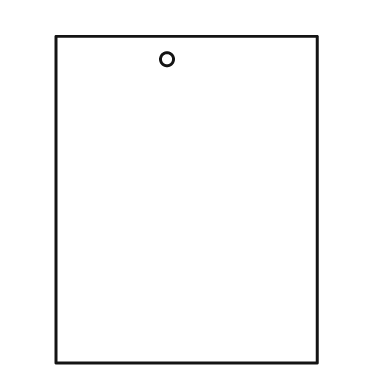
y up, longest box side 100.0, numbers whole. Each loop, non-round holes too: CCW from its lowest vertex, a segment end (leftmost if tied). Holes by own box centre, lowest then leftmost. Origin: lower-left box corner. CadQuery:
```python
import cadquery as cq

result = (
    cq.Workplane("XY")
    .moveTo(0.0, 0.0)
    .lineTo(80.0, 0.0)
    .lineTo(80.0, 100.0)
    .lineTo(0.0, 100.0)
    .close()
    .moveTo(34.0, 93.0)
    .circle(2.0)
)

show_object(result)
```